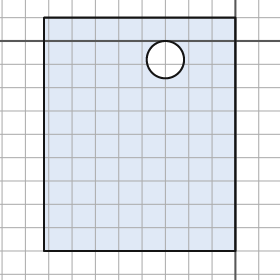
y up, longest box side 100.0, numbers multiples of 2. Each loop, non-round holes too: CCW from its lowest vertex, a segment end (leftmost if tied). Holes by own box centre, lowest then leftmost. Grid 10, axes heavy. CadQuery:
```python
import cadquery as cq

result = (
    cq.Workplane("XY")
    .moveTo(-82.0, -90.0)
    .lineTo(0.0, -90.0)
    .lineTo(0.0, 10.0)
    .lineTo(-82.0, 10.0)
    .close()
    .moveTo(-30.0, -8.0)
    .circle(8.0)
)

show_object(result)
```